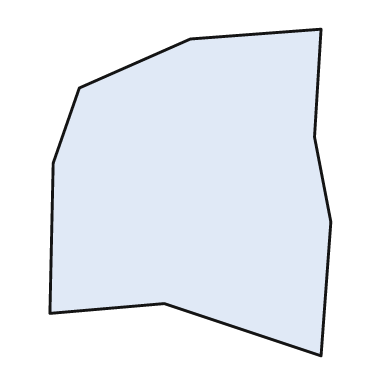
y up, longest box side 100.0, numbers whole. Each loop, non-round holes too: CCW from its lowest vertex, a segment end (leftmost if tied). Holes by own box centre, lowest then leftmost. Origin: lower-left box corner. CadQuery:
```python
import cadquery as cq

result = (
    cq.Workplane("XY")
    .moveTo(83.0, 0.0)
    .lineTo(86.0, 41.0)
    .lineTo(81.0, 67.0)
    .lineTo(83.0, 100.0)
    .lineTo(43.0, 97.0)
    .lineTo(9.0, 82.0)
    .lineTo(1.0, 59.0)
    .lineTo(0.0, 13.0)
    .lineTo(35.0, 16.0)
    .close()
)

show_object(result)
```